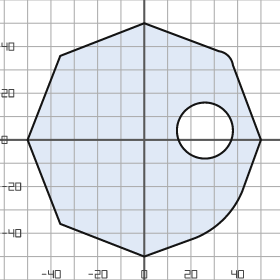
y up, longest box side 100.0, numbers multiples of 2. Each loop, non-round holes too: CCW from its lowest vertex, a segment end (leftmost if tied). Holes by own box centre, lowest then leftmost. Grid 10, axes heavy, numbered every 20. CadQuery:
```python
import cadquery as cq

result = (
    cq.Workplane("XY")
    .moveTo(0.0, -50.0)
    .lineTo(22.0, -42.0)
    .threePointArc((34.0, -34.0), (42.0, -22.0))
    .lineTo(50.0, 0.0)
    .lineTo(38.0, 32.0)
    .threePointArc((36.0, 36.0), (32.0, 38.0))
    .lineTo(0.0, 50.0)
    .lineTo(-36.0, 36.0)
    .lineTo(-50.0, 0.0)
    .lineTo(-36.0, -36.0)
    .close()
    .moveTo(26.0, 4.0)
    .circle(12.0)
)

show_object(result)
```